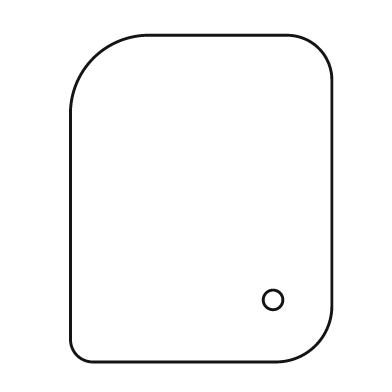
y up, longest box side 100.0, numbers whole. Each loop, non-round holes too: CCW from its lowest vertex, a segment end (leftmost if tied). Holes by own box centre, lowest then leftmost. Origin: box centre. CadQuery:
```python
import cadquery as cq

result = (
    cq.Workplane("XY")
    .moveTo(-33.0, -50.0)
    .lineTo(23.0, -50.0)
    .threePointArc((35.0, -45.0), (40.0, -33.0))
    .lineTo(40.0, 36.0)
    .threePointArc((36.0, 46.0), (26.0, 50.0))
    .lineTo(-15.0, 50.0)
    .threePointArc((-33.0, 43.0), (-40.0, 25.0))
    .lineTo(-40.0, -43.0)
    .threePointArc((-38.0, -48.0), (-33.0, -50.0))
    .close()
    .moveTo(22.0, -31.0)
    .circle(3.0)
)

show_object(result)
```